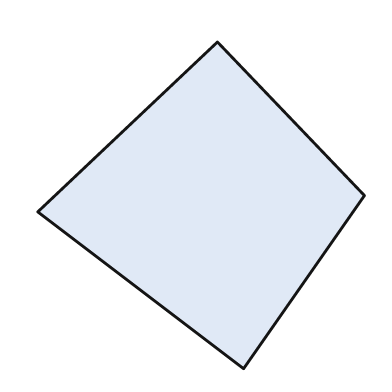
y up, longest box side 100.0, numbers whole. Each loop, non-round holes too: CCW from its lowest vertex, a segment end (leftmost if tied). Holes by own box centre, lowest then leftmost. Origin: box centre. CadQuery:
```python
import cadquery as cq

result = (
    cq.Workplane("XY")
    .moveTo(13.0, -50.0)
    .lineTo(50.0, 3.0)
    .lineTo(5.0, 50.0)
    .lineTo(-50.0, -2.0)
    .close()
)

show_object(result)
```